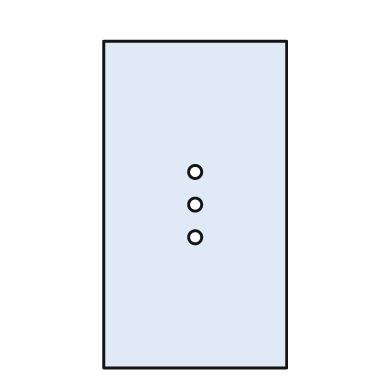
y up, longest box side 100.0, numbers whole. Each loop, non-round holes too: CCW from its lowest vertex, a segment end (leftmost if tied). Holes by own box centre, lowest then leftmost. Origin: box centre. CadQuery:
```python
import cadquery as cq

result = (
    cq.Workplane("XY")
    .moveTo(-28.0, -50.0)
    .lineTo(28.0, -50.0)
    .lineTo(28.0, 50.0)
    .lineTo(-28.0, 50.0)
    .close()
    .moveTo(0.0, -10.0)
    .circle(2.0)
    .moveTo(0.0, 0.0)
    .circle(2.0)
    .moveTo(0.0, 10.0)
    .circle(2.0)
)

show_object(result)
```